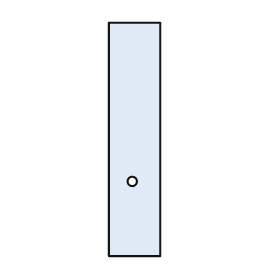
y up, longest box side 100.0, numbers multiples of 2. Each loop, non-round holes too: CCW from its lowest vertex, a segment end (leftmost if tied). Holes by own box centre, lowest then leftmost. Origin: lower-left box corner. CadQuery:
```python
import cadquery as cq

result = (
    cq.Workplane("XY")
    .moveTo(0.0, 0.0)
    .lineTo(22.0, 0.0)
    .lineTo(22.0, 100.0)
    .lineTo(0.0, 100.0)
    .close()
    .moveTo(10.0, 32.0)
    .circle(2.0)
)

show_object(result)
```